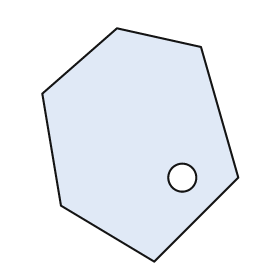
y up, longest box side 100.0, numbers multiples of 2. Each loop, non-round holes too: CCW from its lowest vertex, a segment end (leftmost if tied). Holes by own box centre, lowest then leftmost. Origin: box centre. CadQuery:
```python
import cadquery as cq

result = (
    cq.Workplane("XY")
    .moveTo(6.0, -50.0)
    .lineTo(42.0, -14.0)
    .lineTo(26.0, 42.0)
    .lineTo(-10.0, 50.0)
    .lineTo(-42.0, 22.0)
    .lineTo(-34.0, -26.0)
    .close()
    .moveTo(18.0, -14.0)
    .circle(6.0)
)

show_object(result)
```